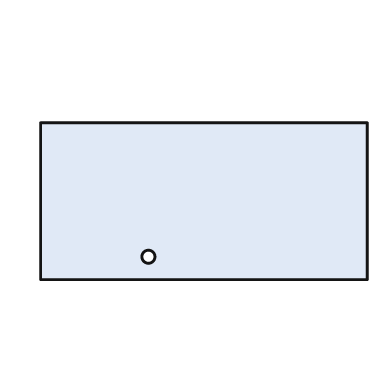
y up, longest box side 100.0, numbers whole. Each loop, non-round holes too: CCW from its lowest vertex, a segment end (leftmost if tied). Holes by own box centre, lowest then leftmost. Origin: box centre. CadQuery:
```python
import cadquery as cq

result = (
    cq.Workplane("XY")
    .moveTo(-50.0, -24.0)
    .lineTo(50.0, -24.0)
    .lineTo(50.0, 24.0)
    .lineTo(-50.0, 24.0)
    .close()
    .moveTo(-17.0, -17.0)
    .circle(2.0)
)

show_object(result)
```